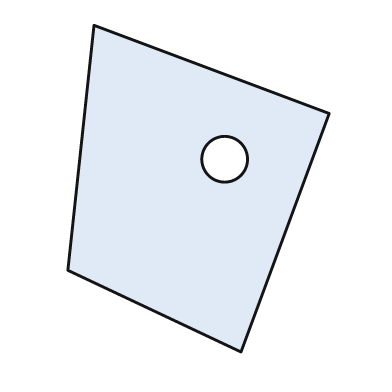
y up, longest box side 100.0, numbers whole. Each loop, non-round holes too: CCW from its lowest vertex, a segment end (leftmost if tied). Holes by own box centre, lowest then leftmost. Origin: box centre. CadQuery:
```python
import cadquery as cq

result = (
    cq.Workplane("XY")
    .moveTo(13.0, -50.0)
    .lineTo(40.0, 23.0)
    .lineTo(-32.0, 50.0)
    .lineTo(-40.0, -25.0)
    .close()
    .moveTo(8.0, 9.0)
    .circle(7.0)
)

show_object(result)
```